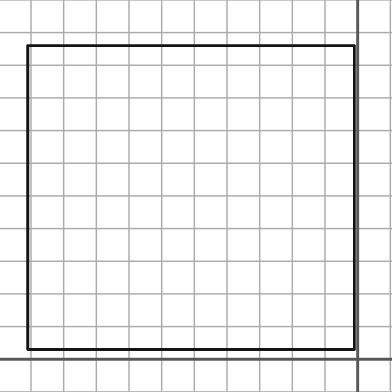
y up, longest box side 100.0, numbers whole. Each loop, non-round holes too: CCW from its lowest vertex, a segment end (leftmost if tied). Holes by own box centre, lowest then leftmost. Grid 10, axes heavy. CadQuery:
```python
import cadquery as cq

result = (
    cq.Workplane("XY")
    .moveTo(-101.0, 3.0)
    .lineTo(-1.0, 3.0)
    .lineTo(-1.0, 96.0)
    .lineTo(-101.0, 96.0)
    .close()
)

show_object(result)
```